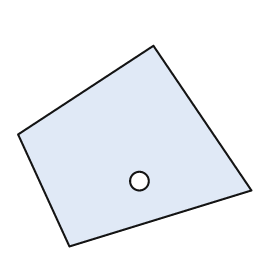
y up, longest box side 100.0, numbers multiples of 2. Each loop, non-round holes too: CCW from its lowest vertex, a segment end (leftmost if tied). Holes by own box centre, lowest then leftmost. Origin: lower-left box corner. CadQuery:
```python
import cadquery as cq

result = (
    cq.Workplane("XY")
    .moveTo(22.0, 0.0)
    .lineTo(100.0, 24.0)
    .lineTo(58.0, 86.0)
    .lineTo(0.0, 48.0)
    .close()
    .moveTo(52.0, 28.0)
    .circle(4.0)
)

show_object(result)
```